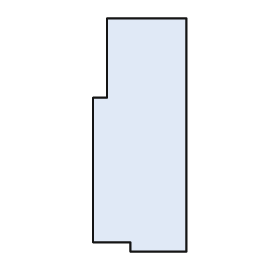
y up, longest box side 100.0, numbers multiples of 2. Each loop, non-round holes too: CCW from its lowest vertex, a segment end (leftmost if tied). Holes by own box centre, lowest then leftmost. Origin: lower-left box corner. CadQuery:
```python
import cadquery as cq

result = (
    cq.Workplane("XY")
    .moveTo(16.0, 0.0)
    .lineTo(40.0, 0.0)
    .lineTo(40.0, 100.0)
    .lineTo(6.0, 100.0)
    .lineTo(6.0, 66.0)
    .lineTo(0.0, 66.0)
    .lineTo(0.0, 4.0)
    .lineTo(16.0, 4.0)
    .close()
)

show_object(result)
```